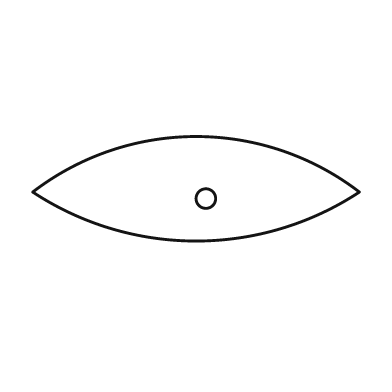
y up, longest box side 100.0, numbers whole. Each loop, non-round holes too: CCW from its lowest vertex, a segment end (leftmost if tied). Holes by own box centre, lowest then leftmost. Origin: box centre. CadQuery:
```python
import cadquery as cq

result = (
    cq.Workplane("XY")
    .moveTo(-50.0, -1.0)
    .threePointArc((0.0, -16.0), (50.0, -1.0))
    .threePointArc((0.0, 16.0), (-50.0, -1.0))
    .close()
    .moveTo(3.0, -3.0)
    .circle(3.0)
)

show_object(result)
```